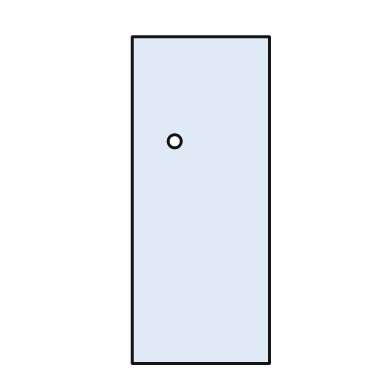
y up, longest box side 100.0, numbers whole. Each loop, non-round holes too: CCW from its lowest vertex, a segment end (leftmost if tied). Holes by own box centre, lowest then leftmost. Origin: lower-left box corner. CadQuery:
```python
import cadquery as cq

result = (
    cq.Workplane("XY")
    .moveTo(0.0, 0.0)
    .lineTo(42.0, 0.0)
    .lineTo(42.0, 100.0)
    .lineTo(0.0, 100.0)
    .close()
    .moveTo(13.0, 68.0)
    .circle(2.0)
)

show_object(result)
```